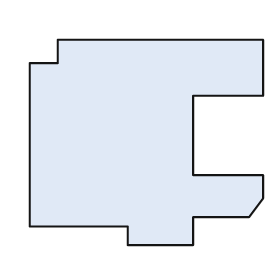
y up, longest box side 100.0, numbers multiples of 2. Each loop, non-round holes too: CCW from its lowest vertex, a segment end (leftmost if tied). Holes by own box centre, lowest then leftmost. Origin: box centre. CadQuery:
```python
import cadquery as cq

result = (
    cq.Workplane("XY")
    .moveTo(-8.0, -44.0)
    .lineTo(20.0, -44.0)
    .lineTo(20.0, -32.0)
    .lineTo(44.0, -32.0)
    .lineTo(50.0, -24.0)
    .lineTo(50.0, -14.0)
    .lineTo(20.0, -14.0)
    .lineTo(20.0, 20.0)
    .lineTo(50.0, 20.0)
    .lineTo(50.0, 44.0)
    .lineTo(-38.0, 44.0)
    .lineTo(-38.0, 34.0)
    .lineTo(-50.0, 34.0)
    .lineTo(-50.0, -36.0)
    .lineTo(-8.0, -36.0)
    .close()
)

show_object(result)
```